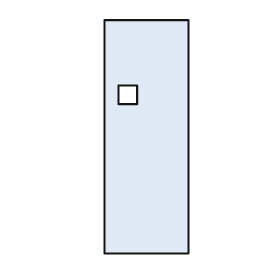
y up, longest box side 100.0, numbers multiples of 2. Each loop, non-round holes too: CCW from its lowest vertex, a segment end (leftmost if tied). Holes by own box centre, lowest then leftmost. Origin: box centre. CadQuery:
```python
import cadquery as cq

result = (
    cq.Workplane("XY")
    .moveTo(-18.0, -50.0)
    .lineTo(18.0, -50.0)
    .lineTo(18.0, 50.0)
    .lineTo(-18.0, 50.0)
    .close()
    .moveTo(-12.0, 14.0)
    .lineTo(-4.0, 14.0)
    .lineTo(-4.0, 22.0)
    .lineTo(-12.0, 22.0)
    .close()
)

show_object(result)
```